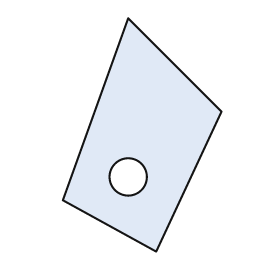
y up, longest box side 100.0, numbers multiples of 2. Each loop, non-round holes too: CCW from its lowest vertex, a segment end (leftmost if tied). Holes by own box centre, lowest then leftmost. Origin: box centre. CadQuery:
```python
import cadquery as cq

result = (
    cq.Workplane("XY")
    .moveTo(6.0, -50.0)
    .lineTo(34.0, 10.0)
    .lineTo(-6.0, 50.0)
    .lineTo(-34.0, -28.0)
    .close()
    .moveTo(-6.0, -18.0)
    .circle(8.0)
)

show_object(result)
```